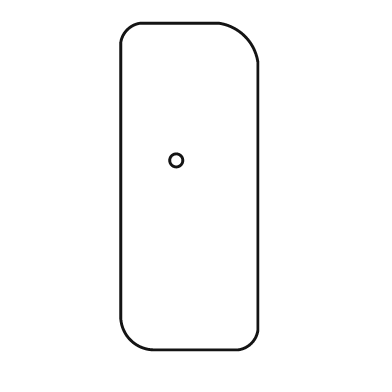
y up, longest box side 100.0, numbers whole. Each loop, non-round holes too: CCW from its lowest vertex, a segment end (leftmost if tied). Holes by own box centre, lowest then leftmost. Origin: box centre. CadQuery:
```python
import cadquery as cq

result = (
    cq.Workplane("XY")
    .moveTo(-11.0, -50.0)
    .lineTo(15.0, -50.0)
    .threePointArc((19.0, -48.0), (21.0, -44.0))
    .lineTo(21.0, 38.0)
    .threePointArc((17.0, 46.0), (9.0, 50.0))
    .lineTo(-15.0, 50.0)
    .threePointArc((-19.0, 48.0), (-21.0, 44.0))
    .lineTo(-21.0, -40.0)
    .threePointArc((-18.0, -47.0), (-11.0, -50.0))
    .close()
    .moveTo(-4.0, 8.0)
    .circle(2.0)
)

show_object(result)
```